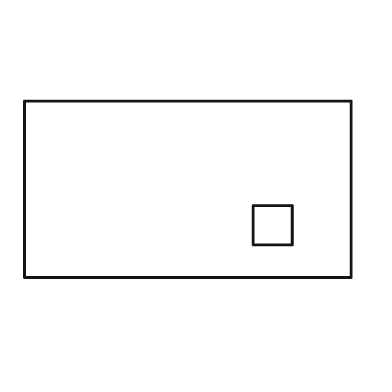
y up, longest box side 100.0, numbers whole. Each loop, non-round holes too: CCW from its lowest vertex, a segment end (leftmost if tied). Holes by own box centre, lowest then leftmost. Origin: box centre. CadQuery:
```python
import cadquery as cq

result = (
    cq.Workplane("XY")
    .moveTo(-50.0, -27.0)
    .lineTo(50.0, -27.0)
    .lineTo(50.0, 27.0)
    .lineTo(-50.0, 27.0)
    .close()
    .moveTo(20.0, -17.0)
    .lineTo(32.0, -17.0)
    .lineTo(32.0, -5.0)
    .lineTo(20.0, -5.0)
    .close()
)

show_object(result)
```